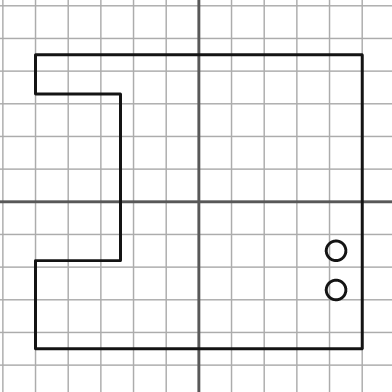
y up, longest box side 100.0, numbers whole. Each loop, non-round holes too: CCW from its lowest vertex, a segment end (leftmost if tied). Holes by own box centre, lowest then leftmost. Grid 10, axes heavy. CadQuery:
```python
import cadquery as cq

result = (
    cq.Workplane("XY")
    .moveTo(-50.0, -45.0)
    .lineTo(50.0, -45.0)
    .lineTo(50.0, 45.0)
    .lineTo(-50.0, 45.0)
    .lineTo(-50.0, 33.0)
    .lineTo(-24.0, 33.0)
    .lineTo(-24.0, -18.0)
    .lineTo(-50.0, -18.0)
    .close()
    .moveTo(42.0, -27.0)
    .circle(3.0)
    .moveTo(42.0, -15.0)
    .circle(3.0)
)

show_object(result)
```